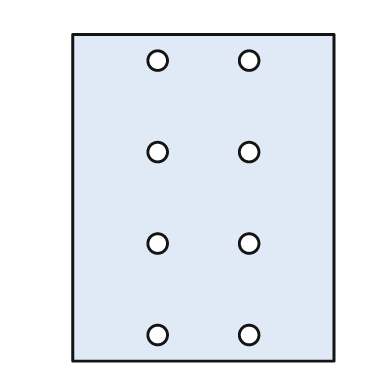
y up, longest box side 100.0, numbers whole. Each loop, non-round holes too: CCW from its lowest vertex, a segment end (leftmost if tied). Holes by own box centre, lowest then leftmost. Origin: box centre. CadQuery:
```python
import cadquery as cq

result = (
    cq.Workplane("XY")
    .moveTo(-40.0, -50.0)
    .lineTo(40.0, -50.0)
    .lineTo(40.0, 50.0)
    .lineTo(-40.0, 50.0)
    .close()
    .moveTo(-14.0, -42.0)
    .circle(3.0)
    .moveTo(14.0, -42.0)
    .circle(3.0)
    .moveTo(-14.0, -14.0)
    .circle(3.0)
    .moveTo(14.0, -14.0)
    .circle(3.0)
    .moveTo(-14.0, 14.0)
    .circle(3.0)
    .moveTo(14.0, 14.0)
    .circle(3.0)
    .moveTo(-14.0, 42.0)
    .circle(3.0)
    .moveTo(14.0, 42.0)
    .circle(3.0)
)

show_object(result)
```